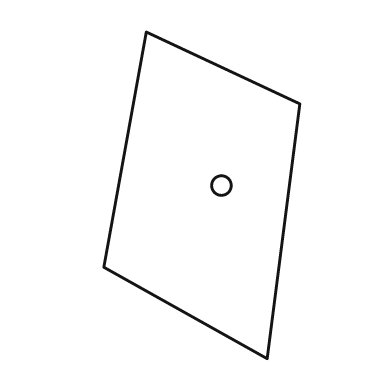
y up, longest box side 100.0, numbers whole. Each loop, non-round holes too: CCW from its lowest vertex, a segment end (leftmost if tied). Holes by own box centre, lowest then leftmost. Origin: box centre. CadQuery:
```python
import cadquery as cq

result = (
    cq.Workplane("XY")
    .moveTo(20.0, -50.0)
    .lineTo(30.0, 28.0)
    .lineTo(-17.0, 50.0)
    .lineTo(-30.0, -22.0)
    .close()
    .moveTo(6.0, 3.0)
    .circle(3.0)
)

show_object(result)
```